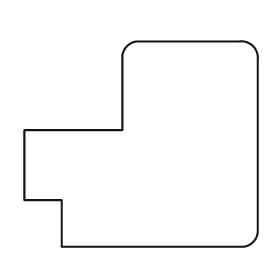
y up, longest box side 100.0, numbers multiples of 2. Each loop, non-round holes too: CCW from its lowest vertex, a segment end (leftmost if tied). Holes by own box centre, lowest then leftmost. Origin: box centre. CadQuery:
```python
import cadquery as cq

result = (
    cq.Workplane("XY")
    .moveTo(-34.0, -44.0)
    .lineTo(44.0, -44.0)
    .threePointArc((48.0, -42.0), (50.0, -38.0))
    .lineTo(50.0, 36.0)
    .threePointArc((48.0, 42.0), (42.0, 44.0))
    .lineTo(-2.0, 44.0)
    .threePointArc((-6.0, 42.0), (-8.0, 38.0))
    .lineTo(-8.0, 6.0)
    .lineTo(-50.0, 6.0)
    .lineTo(-50.0, -24.0)
    .lineTo(-34.0, -24.0)
    .close()
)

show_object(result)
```